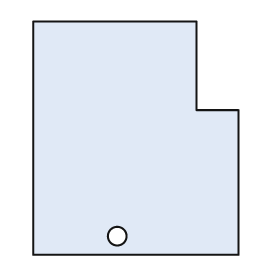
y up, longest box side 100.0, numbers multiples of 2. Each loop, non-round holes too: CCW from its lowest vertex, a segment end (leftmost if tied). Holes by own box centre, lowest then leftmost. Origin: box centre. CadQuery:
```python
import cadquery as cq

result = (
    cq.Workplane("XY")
    .moveTo(-44.0, -50.0)
    .lineTo(44.0, -50.0)
    .lineTo(44.0, 12.0)
    .lineTo(26.0, 12.0)
    .lineTo(26.0, 50.0)
    .lineTo(-44.0, 50.0)
    .close()
    .moveTo(-8.0, -42.0)
    .circle(4.0)
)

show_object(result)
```